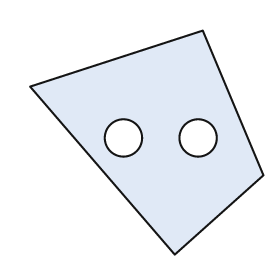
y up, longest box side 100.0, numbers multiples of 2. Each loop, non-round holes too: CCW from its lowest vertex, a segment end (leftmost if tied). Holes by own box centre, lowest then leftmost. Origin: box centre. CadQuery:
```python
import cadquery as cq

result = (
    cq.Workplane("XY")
    .moveTo(12.0, -48.0)
    .lineTo(50.0, -14.0)
    .lineTo(24.0, 48.0)
    .lineTo(-50.0, 24.0)
    .close()
    .moveTo(-10.0, 2.0)
    .circle(8.0)
    .moveTo(22.0, 2.0)
    .circle(8.0)
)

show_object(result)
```